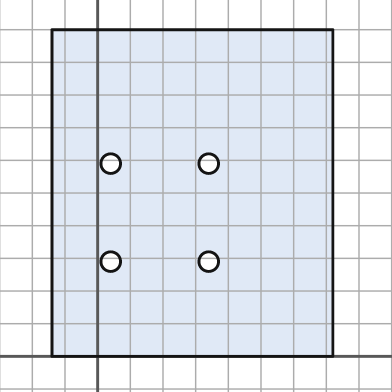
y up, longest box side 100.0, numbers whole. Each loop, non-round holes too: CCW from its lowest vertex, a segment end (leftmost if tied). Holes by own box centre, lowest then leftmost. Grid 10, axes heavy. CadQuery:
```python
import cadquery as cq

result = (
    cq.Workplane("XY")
    .moveTo(-14.0, 0.0)
    .lineTo(72.0, 0.0)
    .lineTo(72.0, 100.0)
    .lineTo(-14.0, 100.0)
    .close()
    .moveTo(4.0, 29.0)
    .circle(3.0)
    .moveTo(34.0, 29.0)
    .circle(3.0)
    .moveTo(4.0, 59.0)
    .circle(3.0)
    .moveTo(34.0, 59.0)
    .circle(3.0)
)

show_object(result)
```